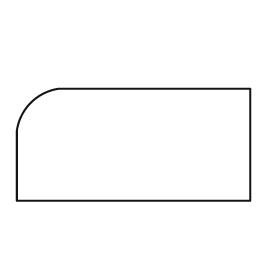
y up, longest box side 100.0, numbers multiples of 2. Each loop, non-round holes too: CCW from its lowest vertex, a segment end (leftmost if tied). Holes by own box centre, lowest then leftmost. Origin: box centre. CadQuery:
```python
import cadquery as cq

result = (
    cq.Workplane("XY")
    .moveTo(-50.0, -24.0)
    .lineTo(50.0, -24.0)
    .lineTo(50.0, 24.0)
    .lineTo(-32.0, 24.0)
    .threePointArc((-44.0, 18.0), (-50.0, 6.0))
    .close()
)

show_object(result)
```